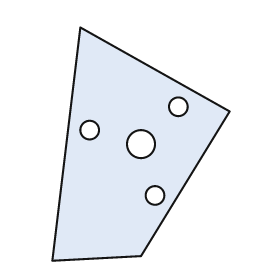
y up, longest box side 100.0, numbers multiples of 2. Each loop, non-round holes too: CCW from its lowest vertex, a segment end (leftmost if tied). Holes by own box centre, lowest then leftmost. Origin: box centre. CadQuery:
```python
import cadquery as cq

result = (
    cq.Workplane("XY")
    .moveTo(-38.0, -50.0)
    .lineTo(0.0, -48.0)
    .lineTo(38.0, 14.0)
    .lineTo(-26.0, 50.0)
    .close()
    .moveTo(6.0, -22.0)
    .circle(4.0)
    .moveTo(0.0, 0.0)
    .circle(6.0)
    .moveTo(-22.0, 6.0)
    .circle(4.0)
    .moveTo(16.0, 16.0)
    .circle(4.0)
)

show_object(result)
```